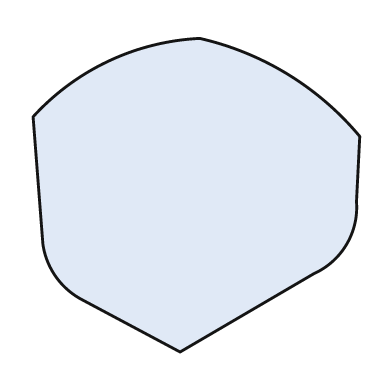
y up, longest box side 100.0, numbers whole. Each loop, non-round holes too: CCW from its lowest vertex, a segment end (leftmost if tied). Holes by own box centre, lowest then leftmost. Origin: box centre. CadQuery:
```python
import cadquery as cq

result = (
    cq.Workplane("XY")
    .moveTo(-5.0, -48.0)
    .lineTo(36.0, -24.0)
    .threePointArc((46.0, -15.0), (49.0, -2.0))
    .lineTo(50.0, 18.0)
    .threePointArc((28.0, 37.0), (1.0, 48.0))
    .threePointArc((-27.0, 41.0), (-50.0, 24.0))
    .lineTo(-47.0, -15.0)
    .threePointArc((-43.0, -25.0), (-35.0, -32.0))
    .close()
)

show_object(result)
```